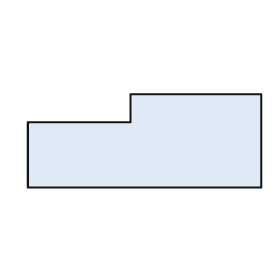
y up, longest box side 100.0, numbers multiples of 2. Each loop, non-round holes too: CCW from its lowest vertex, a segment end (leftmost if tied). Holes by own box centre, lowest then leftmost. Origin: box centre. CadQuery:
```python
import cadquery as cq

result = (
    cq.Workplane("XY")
    .moveTo(-50.0, -20.0)
    .lineTo(50.0, -20.0)
    .lineTo(50.0, 20.0)
    .lineTo(-6.0, 20.0)
    .lineTo(-6.0, 8.0)
    .lineTo(-50.0, 8.0)
    .close()
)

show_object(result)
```